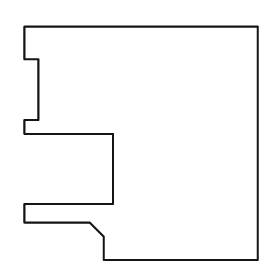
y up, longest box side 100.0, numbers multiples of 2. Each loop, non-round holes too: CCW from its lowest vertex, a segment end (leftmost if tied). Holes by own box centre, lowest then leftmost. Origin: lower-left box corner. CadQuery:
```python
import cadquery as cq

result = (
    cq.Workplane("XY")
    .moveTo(34.0, 0.0)
    .lineTo(100.0, 0.0)
    .lineTo(100.0, 100.0)
    .lineTo(0.0, 100.0)
    .lineTo(0.0, 86.0)
    .lineTo(6.0, 86.0)
    .lineTo(6.0, 60.0)
    .lineTo(0.0, 60.0)
    .lineTo(0.0, 54.0)
    .lineTo(38.0, 54.0)
    .lineTo(38.0, 24.0)
    .lineTo(0.0, 24.0)
    .lineTo(0.0, 16.0)
    .lineTo(28.0, 16.0)
    .lineTo(34.0, 10.0)
    .close()
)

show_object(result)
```